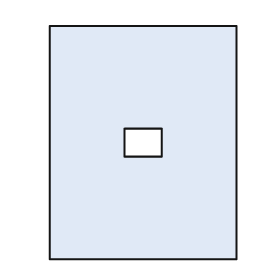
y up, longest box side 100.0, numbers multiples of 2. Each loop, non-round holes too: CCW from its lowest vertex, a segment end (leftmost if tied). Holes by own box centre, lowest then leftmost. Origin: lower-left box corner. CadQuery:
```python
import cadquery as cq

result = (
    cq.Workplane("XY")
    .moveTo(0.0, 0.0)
    .lineTo(80.0, 0.0)
    .lineTo(80.0, 100.0)
    .lineTo(0.0, 100.0)
    .close()
    .moveTo(32.0, 44.0)
    .lineTo(48.0, 44.0)
    .lineTo(48.0, 56.0)
    .lineTo(32.0, 56.0)
    .close()
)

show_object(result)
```